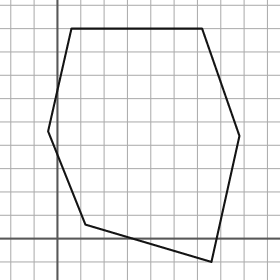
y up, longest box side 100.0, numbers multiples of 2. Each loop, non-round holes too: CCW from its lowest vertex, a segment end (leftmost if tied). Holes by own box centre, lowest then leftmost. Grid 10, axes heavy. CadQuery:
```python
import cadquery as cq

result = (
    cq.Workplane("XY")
    .moveTo(66.0, -10.0)
    .lineTo(78.0, 44.0)
    .lineTo(62.0, 90.0)
    .lineTo(6.0, 90.0)
    .lineTo(-4.0, 46.0)
    .lineTo(12.0, 6.0)
    .close()
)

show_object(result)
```